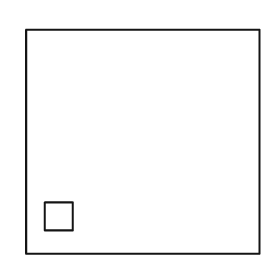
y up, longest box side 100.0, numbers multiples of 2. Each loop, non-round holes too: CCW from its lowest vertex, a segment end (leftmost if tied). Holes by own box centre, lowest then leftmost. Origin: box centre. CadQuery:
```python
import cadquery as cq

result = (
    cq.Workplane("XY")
    .moveTo(-50.0, -48.0)
    .lineTo(50.0, -48.0)
    .lineTo(50.0, 48.0)
    .lineTo(-50.0, 48.0)
    .close()
    .moveTo(-42.0, -38.0)
    .lineTo(-30.0, -38.0)
    .lineTo(-30.0, -26.0)
    .lineTo(-42.0, -26.0)
    .close()
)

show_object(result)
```